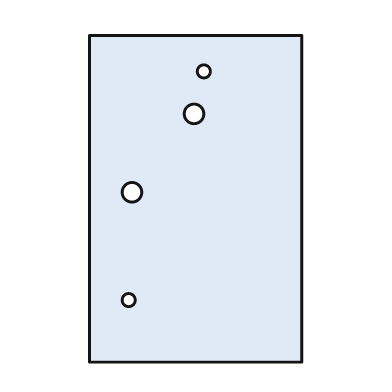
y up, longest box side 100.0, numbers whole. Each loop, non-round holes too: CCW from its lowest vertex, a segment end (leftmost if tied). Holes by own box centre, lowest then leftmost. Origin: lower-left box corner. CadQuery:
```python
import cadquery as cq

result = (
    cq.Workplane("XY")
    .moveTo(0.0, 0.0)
    .lineTo(65.0, 0.0)
    .lineTo(65.0, 100.0)
    .lineTo(0.0, 100.0)
    .close()
    .moveTo(12.0, 19.0)
    .circle(2.0)
    .moveTo(13.0, 52.0)
    .circle(3.0)
    .moveTo(32.0, 76.0)
    .circle(3.0)
    .moveTo(35.0, 89.0)
    .circle(2.0)
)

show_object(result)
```